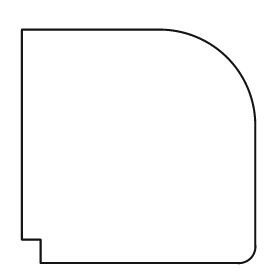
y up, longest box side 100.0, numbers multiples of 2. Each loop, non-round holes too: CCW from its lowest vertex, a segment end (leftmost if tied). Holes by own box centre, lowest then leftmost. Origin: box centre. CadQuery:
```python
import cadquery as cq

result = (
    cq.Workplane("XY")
    .moveTo(-42.0, -50.0)
    .lineTo(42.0, -50.0)
    .threePointArc((48.0, -48.0), (50.0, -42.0))
    .lineTo(50.0, 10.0)
    .threePointArc((38.0, 38.0), (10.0, 50.0))
    .lineTo(-50.0, 50.0)
    .lineTo(-50.0, -40.0)
    .lineTo(-42.0, -40.0)
    .close()
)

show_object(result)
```